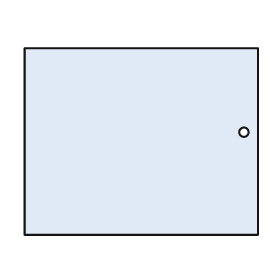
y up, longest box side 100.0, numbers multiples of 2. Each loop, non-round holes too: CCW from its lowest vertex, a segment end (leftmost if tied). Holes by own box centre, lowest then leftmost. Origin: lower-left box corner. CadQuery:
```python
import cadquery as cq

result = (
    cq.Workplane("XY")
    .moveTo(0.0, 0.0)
    .lineTo(100.0, 0.0)
    .lineTo(100.0, 80.0)
    .lineTo(0.0, 80.0)
    .close()
    .moveTo(94.0, 44.0)
    .circle(2.0)
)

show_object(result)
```